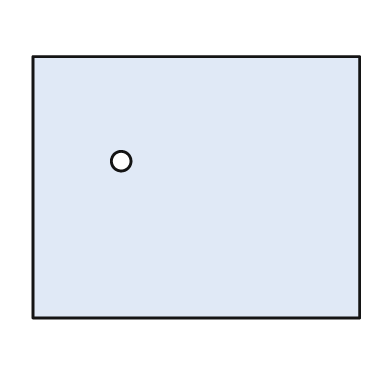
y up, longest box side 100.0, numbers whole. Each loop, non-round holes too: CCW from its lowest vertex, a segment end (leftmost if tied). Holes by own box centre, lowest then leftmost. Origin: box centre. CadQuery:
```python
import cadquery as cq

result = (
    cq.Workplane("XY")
    .moveTo(-50.0, -40.0)
    .lineTo(50.0, -40.0)
    .lineTo(50.0, 40.0)
    .lineTo(-50.0, 40.0)
    .close()
    .moveTo(-23.0, 8.0)
    .circle(3.0)
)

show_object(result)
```